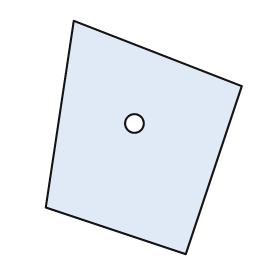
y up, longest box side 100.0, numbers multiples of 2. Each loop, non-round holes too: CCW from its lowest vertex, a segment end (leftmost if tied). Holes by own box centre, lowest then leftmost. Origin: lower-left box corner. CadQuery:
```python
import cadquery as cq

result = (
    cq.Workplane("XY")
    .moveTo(60.0, 0.0)
    .lineTo(84.0, 72.0)
    .lineTo(12.0, 100.0)
    .lineTo(0.0, 20.0)
    .close()
    .moveTo(38.0, 56.0)
    .circle(4.0)
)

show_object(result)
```